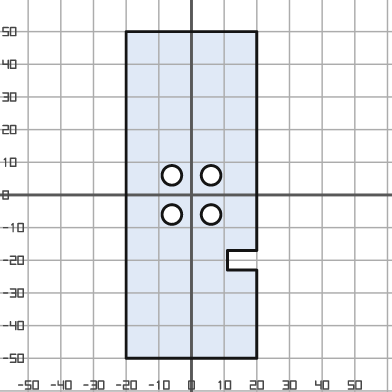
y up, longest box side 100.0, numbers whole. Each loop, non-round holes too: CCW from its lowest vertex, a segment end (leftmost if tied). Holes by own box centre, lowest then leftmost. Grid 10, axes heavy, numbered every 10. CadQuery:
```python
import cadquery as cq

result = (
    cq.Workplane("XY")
    .moveTo(-20.0, -50.0)
    .lineTo(20.0, -50.0)
    .lineTo(20.0, -23.0)
    .lineTo(11.0, -23.0)
    .lineTo(11.0, -17.0)
    .lineTo(20.0, -17.0)
    .lineTo(20.0, 50.0)
    .lineTo(-20.0, 50.0)
    .close()
    .moveTo(-6.0, -6.0)
    .circle(3.0)
    .moveTo(6.0, -6.0)
    .circle(3.0)
    .moveTo(-6.0, 6.0)
    .circle(3.0)
    .moveTo(6.0, 6.0)
    .circle(3.0)
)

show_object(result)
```